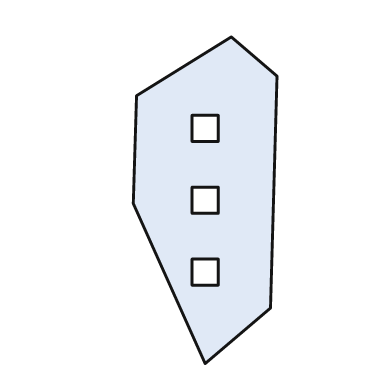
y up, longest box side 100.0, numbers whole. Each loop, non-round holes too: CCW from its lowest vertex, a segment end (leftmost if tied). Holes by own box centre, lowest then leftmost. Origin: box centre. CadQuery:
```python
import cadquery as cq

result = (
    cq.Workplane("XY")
    .moveTo(0.0, -50.0)
    .lineTo(20.0, -33.0)
    .lineTo(22.0, 38.0)
    .lineTo(8.0, 50.0)
    .lineTo(-21.0, 32.0)
    .lineTo(-22.0, -1.0)
    .close()
    .moveTo(-4.0, -26.0)
    .lineTo(4.0, -26.0)
    .lineTo(4.0, -18.0)
    .lineTo(-4.0, -18.0)
    .close()
    .moveTo(-4.0, -4.0)
    .lineTo(4.0, -4.0)
    .lineTo(4.0, 4.0)
    .lineTo(-4.0, 4.0)
    .close()
    .moveTo(-4.0, 18.0)
    .lineTo(4.0, 18.0)
    .lineTo(4.0, 26.0)
    .lineTo(-4.0, 26.0)
    .close()
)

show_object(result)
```